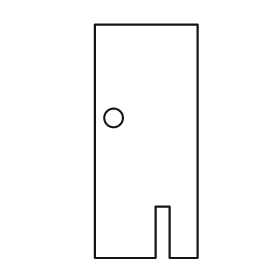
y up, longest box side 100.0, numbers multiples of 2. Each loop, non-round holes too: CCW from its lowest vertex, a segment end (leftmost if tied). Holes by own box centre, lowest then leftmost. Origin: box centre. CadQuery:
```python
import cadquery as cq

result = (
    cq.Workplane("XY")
    .moveTo(-22.0, -50.0)
    .lineTo(4.0, -50.0)
    .lineTo(4.0, -28.0)
    .lineTo(10.0, -28.0)
    .lineTo(10.0, -50.0)
    .lineTo(22.0, -50.0)
    .lineTo(22.0, 50.0)
    .lineTo(-22.0, 50.0)
    .close()
    .moveTo(-14.0, 10.0)
    .circle(4.0)
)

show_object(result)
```